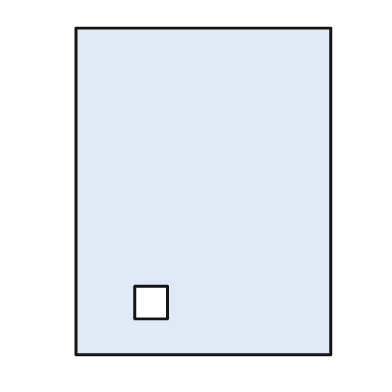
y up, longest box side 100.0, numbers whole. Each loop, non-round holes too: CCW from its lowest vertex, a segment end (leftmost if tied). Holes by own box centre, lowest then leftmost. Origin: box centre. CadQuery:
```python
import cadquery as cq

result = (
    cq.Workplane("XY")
    .moveTo(-39.0, -50.0)
    .lineTo(39.0, -50.0)
    .lineTo(39.0, 50.0)
    .lineTo(-39.0, 50.0)
    .close()
    .moveTo(-21.0, -39.0)
    .lineTo(-11.0, -39.0)
    .lineTo(-11.0, -29.0)
    .lineTo(-21.0, -29.0)
    .close()
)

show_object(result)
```